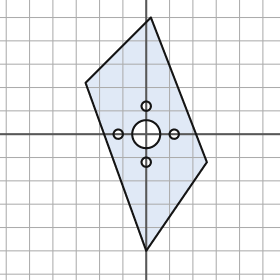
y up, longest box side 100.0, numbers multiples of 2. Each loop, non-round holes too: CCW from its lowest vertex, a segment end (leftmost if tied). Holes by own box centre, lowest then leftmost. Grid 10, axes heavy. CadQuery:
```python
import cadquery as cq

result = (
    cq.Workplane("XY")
    .moveTo(0.0, -50.0)
    .lineTo(26.0, -12.0)
    .lineTo(2.0, 50.0)
    .lineTo(-26.0, 22.0)
    .close()
    .moveTo(0.0, -12.0)
    .circle(2.0)
    .moveTo(-12.0, 0.0)
    .circle(2.0)
    .moveTo(0.0, 0.0)
    .circle(6.0)
    .moveTo(12.0, 0.0)
    .circle(2.0)
    .moveTo(0.0, 12.0)
    .circle(2.0)
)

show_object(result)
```